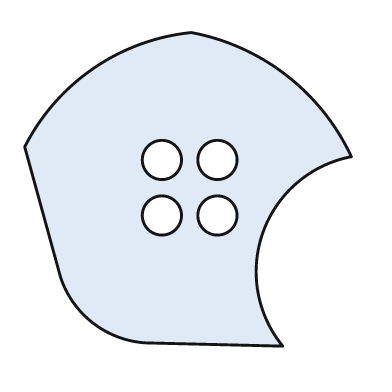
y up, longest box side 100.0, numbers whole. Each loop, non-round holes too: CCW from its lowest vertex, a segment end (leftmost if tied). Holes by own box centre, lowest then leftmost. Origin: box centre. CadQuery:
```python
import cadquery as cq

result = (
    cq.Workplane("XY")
    .moveTo(29.0, -48.0)
    .threePointArc((23.0, -13.0), (50.0, 10.0))
    .threePointArc((30.0, 35.0), (1.0, 48.0))
    .threePointArc((-29.0, 37.0), (-50.0, 13.0))
    .lineTo(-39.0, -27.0)
    .threePointArc((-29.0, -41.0), (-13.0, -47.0))
    .close()
    .moveTo(-8.0, -8.0)
    .circle(6.0)
    .moveTo(9.0, -8.0)
    .circle(6.0)
    .moveTo(-8.0, 9.0)
    .circle(6.0)
    .moveTo(9.0, 9.0)
    .circle(6.0)
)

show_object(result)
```